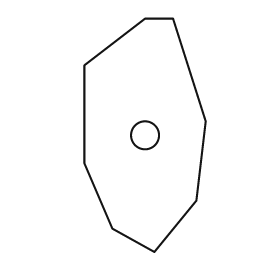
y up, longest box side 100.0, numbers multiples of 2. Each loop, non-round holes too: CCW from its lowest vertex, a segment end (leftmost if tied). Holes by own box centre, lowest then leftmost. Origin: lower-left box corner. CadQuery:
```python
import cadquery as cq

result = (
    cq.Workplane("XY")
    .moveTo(30.0, 0.0)
    .lineTo(48.0, 22.0)
    .lineTo(52.0, 56.0)
    .lineTo(38.0, 100.0)
    .lineTo(26.0, 100.0)
    .lineTo(0.0, 80.0)
    .lineTo(0.0, 38.0)
    .lineTo(12.0, 10.0)
    .close()
    .moveTo(26.0, 50.0)
    .circle(6.0)
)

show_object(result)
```